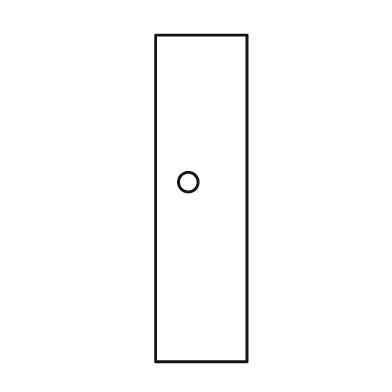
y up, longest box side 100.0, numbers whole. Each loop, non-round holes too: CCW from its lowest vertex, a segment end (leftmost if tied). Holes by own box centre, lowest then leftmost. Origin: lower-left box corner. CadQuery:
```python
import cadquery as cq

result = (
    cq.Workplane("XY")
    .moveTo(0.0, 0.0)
    .lineTo(28.0, 0.0)
    .lineTo(28.0, 100.0)
    .lineTo(0.0, 100.0)
    .close()
    .moveTo(10.0, 55.0)
    .circle(3.0)
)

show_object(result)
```